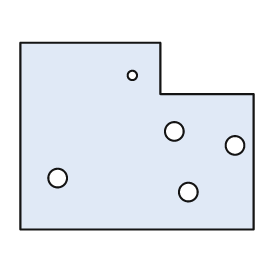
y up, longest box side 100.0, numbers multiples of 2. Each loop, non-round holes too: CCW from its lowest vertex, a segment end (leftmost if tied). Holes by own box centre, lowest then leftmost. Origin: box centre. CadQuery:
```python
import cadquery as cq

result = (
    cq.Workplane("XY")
    .moveTo(-50.0, -40.0)
    .lineTo(50.0, -40.0)
    .lineTo(50.0, 18.0)
    .lineTo(10.0, 18.0)
    .lineTo(10.0, 40.0)
    .lineTo(-50.0, 40.0)
    .close()
    .moveTo(22.0, -24.0)
    .circle(4.0)
    .moveTo(-34.0, -18.0)
    .circle(4.0)
    .moveTo(42.0, -4.0)
    .circle(4.0)
    .moveTo(16.0, 2.0)
    .circle(4.0)
    .moveTo(-2.0, 26.0)
    .circle(2.0)
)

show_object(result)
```